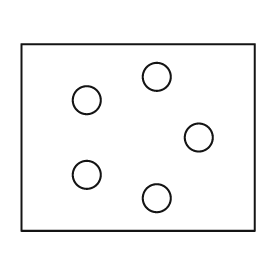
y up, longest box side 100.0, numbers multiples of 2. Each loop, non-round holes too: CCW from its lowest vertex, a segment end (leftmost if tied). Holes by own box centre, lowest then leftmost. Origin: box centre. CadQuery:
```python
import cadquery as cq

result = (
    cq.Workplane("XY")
    .moveTo(-50.0, -40.0)
    .lineTo(50.0, -40.0)
    .lineTo(50.0, 40.0)
    .lineTo(-50.0, 40.0)
    .close()
    .moveTo(8.0, -26.0)
    .circle(6.0)
    .moveTo(-22.0, -16.0)
    .circle(6.0)
    .moveTo(26.0, 0.0)
    .circle(6.0)
    .moveTo(-22.0, 16.0)
    .circle(6.0)
    .moveTo(8.0, 26.0)
    .circle(6.0)
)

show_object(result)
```